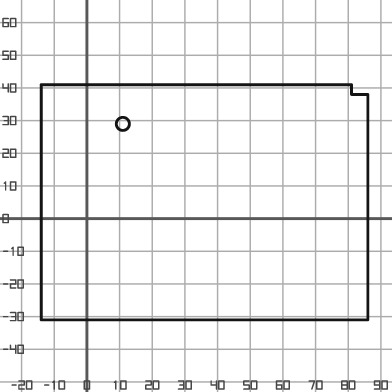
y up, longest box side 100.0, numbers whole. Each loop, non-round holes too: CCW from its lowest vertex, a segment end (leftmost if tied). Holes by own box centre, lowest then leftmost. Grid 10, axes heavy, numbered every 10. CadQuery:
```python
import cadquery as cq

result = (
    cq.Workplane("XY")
    .moveTo(-14.0, -31.0)
    .lineTo(86.0, -31.0)
    .lineTo(86.0, 38.0)
    .lineTo(81.0, 38.0)
    .lineTo(81.0, 41.0)
    .lineTo(-14.0, 41.0)
    .close()
    .moveTo(11.0, 29.0)
    .circle(2.0)
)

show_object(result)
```